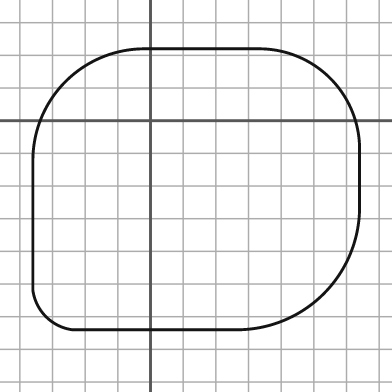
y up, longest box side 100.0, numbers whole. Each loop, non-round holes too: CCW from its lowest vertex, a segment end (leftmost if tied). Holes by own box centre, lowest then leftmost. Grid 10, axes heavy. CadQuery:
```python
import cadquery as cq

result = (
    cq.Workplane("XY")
    .moveTo(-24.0, -64.0)
    .lineTo(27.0, -64.0)
    .threePointArc((53.0, -53.0), (64.0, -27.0))
    .lineTo(64.0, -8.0)
    .threePointArc((55.0, 13.0), (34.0, 22.0))
    .lineTo(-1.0, 22.0)
    .threePointArc((-26.0, 12.0), (-36.0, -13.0))
    .lineTo(-36.0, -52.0)
    .threePointArc((-32.0, -60.0), (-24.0, -64.0))
    .close()
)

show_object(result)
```